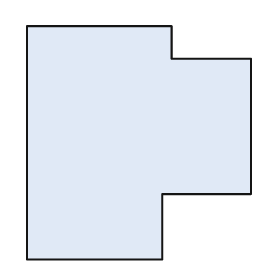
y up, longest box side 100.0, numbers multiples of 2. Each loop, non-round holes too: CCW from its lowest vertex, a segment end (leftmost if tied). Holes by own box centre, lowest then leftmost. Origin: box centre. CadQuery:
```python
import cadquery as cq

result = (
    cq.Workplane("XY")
    .moveTo(-48.0, -50.0)
    .lineTo(10.0, -50.0)
    .lineTo(10.0, -22.0)
    .lineTo(48.0, -22.0)
    .lineTo(48.0, 36.0)
    .lineTo(14.0, 36.0)
    .lineTo(14.0, 50.0)
    .lineTo(-48.0, 50.0)
    .close()
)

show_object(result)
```